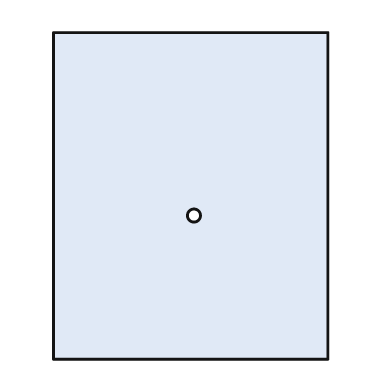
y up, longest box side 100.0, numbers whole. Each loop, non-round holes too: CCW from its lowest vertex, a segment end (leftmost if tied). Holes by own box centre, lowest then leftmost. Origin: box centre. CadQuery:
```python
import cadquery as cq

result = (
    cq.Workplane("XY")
    .moveTo(-42.0, -50.0)
    .lineTo(42.0, -50.0)
    .lineTo(42.0, 50.0)
    .lineTo(-42.0, 50.0)
    .close()
    .moveTo(1.0, -6.0)
    .circle(2.0)
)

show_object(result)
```